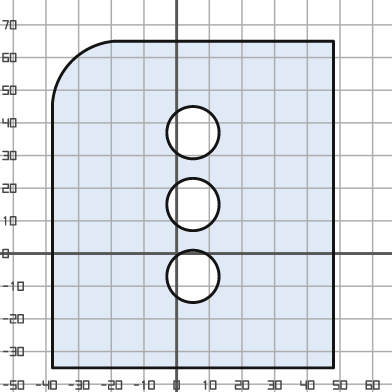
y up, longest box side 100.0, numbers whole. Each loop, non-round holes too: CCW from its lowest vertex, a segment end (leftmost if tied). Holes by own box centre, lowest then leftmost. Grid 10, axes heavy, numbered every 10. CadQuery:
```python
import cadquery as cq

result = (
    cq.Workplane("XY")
    .moveTo(-38.0, -35.0)
    .lineTo(48.0, -35.0)
    .lineTo(48.0, 65.0)
    .lineTo(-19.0, 65.0)
    .threePointArc((-32.0, 59.0), (-38.0, 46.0))
    .close()
    .moveTo(5.0, -7.0)
    .circle(8.0)
    .moveTo(5.0, 15.0)
    .circle(8.0)
    .moveTo(5.0, 37.0)
    .circle(8.0)
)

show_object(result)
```